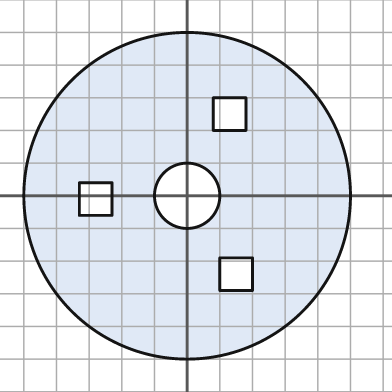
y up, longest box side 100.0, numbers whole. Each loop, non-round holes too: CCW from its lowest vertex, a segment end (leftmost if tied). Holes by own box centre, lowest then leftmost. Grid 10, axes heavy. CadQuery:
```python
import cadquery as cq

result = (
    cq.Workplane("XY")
    .moveTo(0.0, 0.0)
    .circle(50.0)
    .moveTo(10.0, -29.0)
    .lineTo(20.0, -29.0)
    .lineTo(20.0, -19.0)
    .lineTo(10.0, -19.0)
    .close()
    .moveTo(-33.0, -6.0)
    .lineTo(-23.0, -6.0)
    .lineTo(-23.0, 4.0)
    .lineTo(-33.0, 4.0)
    .close()
    .moveTo(0.0, 0.0)
    .circle(10.0)
    .moveTo(8.0, 20.0)
    .lineTo(18.0, 20.0)
    .lineTo(18.0, 30.0)
    .lineTo(8.0, 30.0)
    .close()
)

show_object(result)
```